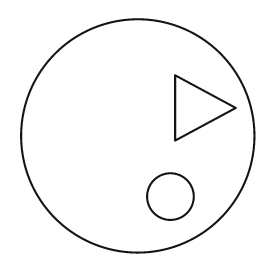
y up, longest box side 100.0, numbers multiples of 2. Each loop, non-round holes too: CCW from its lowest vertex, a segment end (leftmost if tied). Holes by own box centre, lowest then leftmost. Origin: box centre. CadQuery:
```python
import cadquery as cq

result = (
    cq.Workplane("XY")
    .moveTo(0.0, 0.0)
    .circle(50.0)
    .moveTo(14.0, -26.0)
    .circle(10.0)
    .moveTo(16.0, -2.0)
    .lineTo(42.0, 12.0)
    .lineTo(16.0, 26.0)
    .close()
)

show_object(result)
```